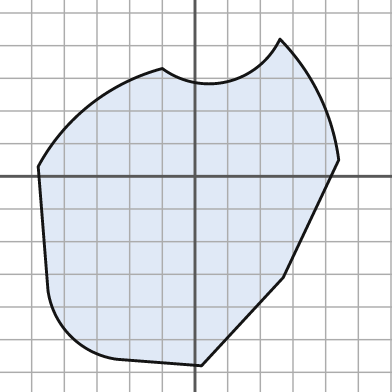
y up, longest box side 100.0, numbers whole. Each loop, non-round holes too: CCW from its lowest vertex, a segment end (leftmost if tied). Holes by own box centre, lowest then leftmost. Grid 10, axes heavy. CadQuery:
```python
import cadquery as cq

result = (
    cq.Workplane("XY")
    .moveTo(2.0, -58.0)
    .lineTo(27.0, -31.0)
    .lineTo(44.0, 5.0)
    .threePointArc((38.0, 25.0), (26.0, 42.0))
    .threePointArc((10.0, 29.0), (-10.0, 33.0))
    .threePointArc((-32.0, 22.0), (-48.0, 3.0))
    .lineTo(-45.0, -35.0)
    .threePointArc((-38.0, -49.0), (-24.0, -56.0))
    .close()
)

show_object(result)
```